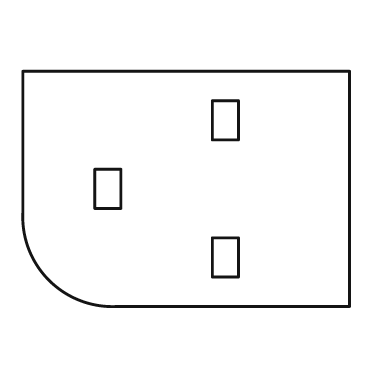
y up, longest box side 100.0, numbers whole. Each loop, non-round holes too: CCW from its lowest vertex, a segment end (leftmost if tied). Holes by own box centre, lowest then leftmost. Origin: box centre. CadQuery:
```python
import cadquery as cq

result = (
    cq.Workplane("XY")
    .moveTo(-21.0, -36.0)
    .lineTo(50.0, -36.0)
    .lineTo(50.0, 36.0)
    .lineTo(-50.0, 36.0)
    .lineTo(-50.0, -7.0)
    .threePointArc((-42.0, -28.0), (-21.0, -36.0))
    .close()
    .moveTo(8.0, -27.0)
    .lineTo(16.0, -27.0)
    .lineTo(16.0, -15.0)
    .lineTo(8.0, -15.0)
    .close()
    .moveTo(-28.0, -6.0)
    .lineTo(-20.0, -6.0)
    .lineTo(-20.0, 6.0)
    .lineTo(-28.0, 6.0)
    .close()
    .moveTo(8.0, 15.0)
    .lineTo(16.0, 15.0)
    .lineTo(16.0, 27.0)
    .lineTo(8.0, 27.0)
    .close()
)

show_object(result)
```